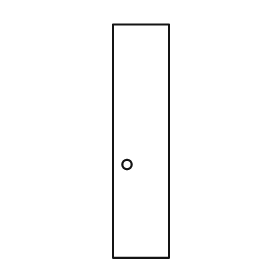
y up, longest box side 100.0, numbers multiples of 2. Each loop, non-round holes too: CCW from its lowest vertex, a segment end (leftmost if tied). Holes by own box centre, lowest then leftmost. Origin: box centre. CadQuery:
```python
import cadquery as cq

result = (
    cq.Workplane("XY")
    .moveTo(-12.0, -50.0)
    .lineTo(12.0, -50.0)
    .lineTo(12.0, 50.0)
    .lineTo(-12.0, 50.0)
    .close()
    .moveTo(-6.0, -10.0)
    .circle(2.0)
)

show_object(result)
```